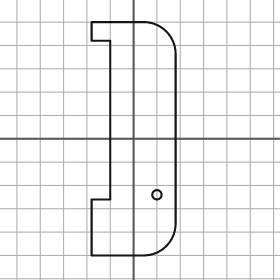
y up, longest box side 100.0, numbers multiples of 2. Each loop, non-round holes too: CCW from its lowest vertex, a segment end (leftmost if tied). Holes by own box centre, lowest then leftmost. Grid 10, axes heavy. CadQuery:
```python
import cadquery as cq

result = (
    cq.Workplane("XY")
    .moveTo(-18.0, -50.0)
    .lineTo(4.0, -50.0)
    .threePointArc((14.0, -46.0), (18.0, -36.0))
    .lineTo(18.0, 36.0)
    .threePointArc((14.0, 46.0), (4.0, 50.0))
    .lineTo(-18.0, 50.0)
    .lineTo(-18.0, 42.0)
    .lineTo(-10.0, 42.0)
    .lineTo(-10.0, -26.0)
    .lineTo(-18.0, -26.0)
    .close()
    .moveTo(10.0, -24.0)
    .circle(2.0)
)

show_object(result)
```